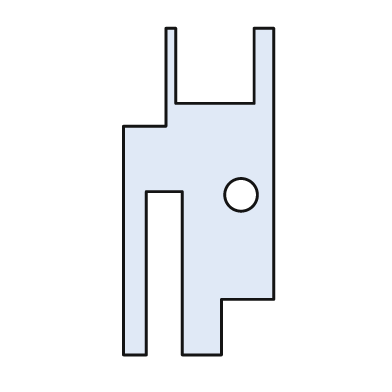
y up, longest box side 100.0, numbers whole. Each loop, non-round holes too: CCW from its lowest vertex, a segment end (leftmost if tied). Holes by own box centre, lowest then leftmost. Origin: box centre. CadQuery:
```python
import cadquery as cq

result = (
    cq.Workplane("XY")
    .moveTo(-23.0, -50.0)
    .lineTo(-16.0, -50.0)
    .lineTo(-16.0, 0.0)
    .lineTo(-5.0, 0.0)
    .lineTo(-5.0, -50.0)
    .lineTo(7.0, -50.0)
    .lineTo(7.0, -33.0)
    .lineTo(23.0, -33.0)
    .lineTo(23.0, 50.0)
    .lineTo(17.0, 50.0)
    .lineTo(17.0, 27.0)
    .lineTo(-7.0, 27.0)
    .lineTo(-7.0, 50.0)
    .lineTo(-10.0, 50.0)
    .lineTo(-10.0, 20.0)
    .lineTo(-23.0, 20.0)
    .close()
    .moveTo(13.0, -1.0)
    .circle(5.0)
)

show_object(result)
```